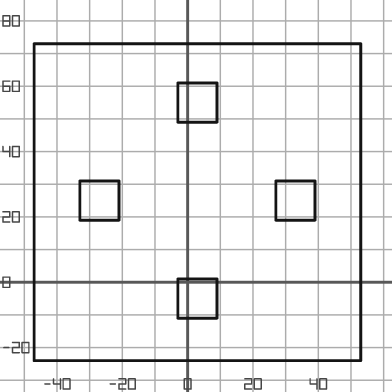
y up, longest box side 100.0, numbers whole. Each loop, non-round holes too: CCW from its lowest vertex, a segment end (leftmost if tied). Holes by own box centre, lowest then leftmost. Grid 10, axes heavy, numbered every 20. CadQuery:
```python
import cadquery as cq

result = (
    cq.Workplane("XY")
    .moveTo(-47.0, -24.0)
    .lineTo(53.0, -24.0)
    .lineTo(53.0, 73.0)
    .lineTo(-47.0, 73.0)
    .close()
    .moveTo(-3.0, -11.0)
    .lineTo(9.0, -11.0)
    .lineTo(9.0, 1.0)
    .lineTo(-3.0, 1.0)
    .close()
    .moveTo(-33.0, 19.0)
    .lineTo(-21.0, 19.0)
    .lineTo(-21.0, 31.0)
    .lineTo(-33.0, 31.0)
    .close()
    .moveTo(27.0, 19.0)
    .lineTo(39.0, 19.0)
    .lineTo(39.0, 31.0)
    .lineTo(27.0, 31.0)
    .close()
    .moveTo(-3.0, 49.0)
    .lineTo(9.0, 49.0)
    .lineTo(9.0, 61.0)
    .lineTo(-3.0, 61.0)
    .close()
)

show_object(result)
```